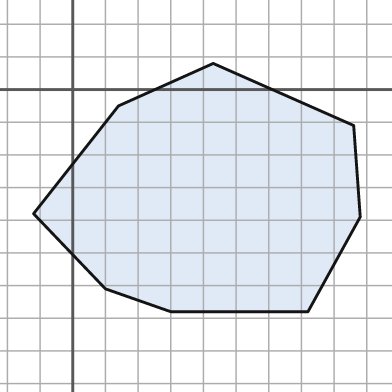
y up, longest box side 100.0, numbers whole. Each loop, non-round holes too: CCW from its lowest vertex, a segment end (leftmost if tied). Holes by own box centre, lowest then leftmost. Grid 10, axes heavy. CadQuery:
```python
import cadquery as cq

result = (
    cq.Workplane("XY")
    .moveTo(30.0, -68.0)
    .lineTo(72.0, -68.0)
    .lineTo(88.0, -39.0)
    .lineTo(86.0, -11.0)
    .lineTo(43.0, 8.0)
    .lineTo(14.0, -5.0)
    .lineTo(-12.0, -38.0)
    .lineTo(10.0, -61.0)
    .close()
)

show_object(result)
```